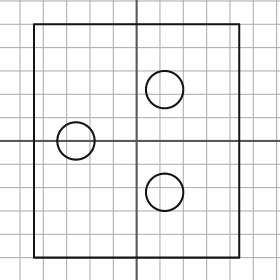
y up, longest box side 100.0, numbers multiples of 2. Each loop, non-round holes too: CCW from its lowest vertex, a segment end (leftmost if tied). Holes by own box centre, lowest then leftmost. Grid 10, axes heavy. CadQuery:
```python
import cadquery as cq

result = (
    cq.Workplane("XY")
    .moveTo(-44.0, -50.0)
    .lineTo(44.0, -50.0)
    .lineTo(44.0, 50.0)
    .lineTo(-44.0, 50.0)
    .close()
    .moveTo(12.0, -22.0)
    .circle(8.0)
    .moveTo(-26.0, 0.0)
    .circle(8.0)
    .moveTo(12.0, 22.0)
    .circle(8.0)
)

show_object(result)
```